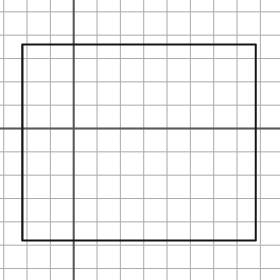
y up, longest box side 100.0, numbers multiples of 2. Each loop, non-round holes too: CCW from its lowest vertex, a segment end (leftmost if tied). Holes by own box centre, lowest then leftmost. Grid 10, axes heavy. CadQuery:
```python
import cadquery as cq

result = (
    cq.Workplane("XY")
    .moveTo(-22.0, -48.0)
    .lineTo(78.0, -48.0)
    .lineTo(78.0, 36.0)
    .lineTo(-22.0, 36.0)
    .close()
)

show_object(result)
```